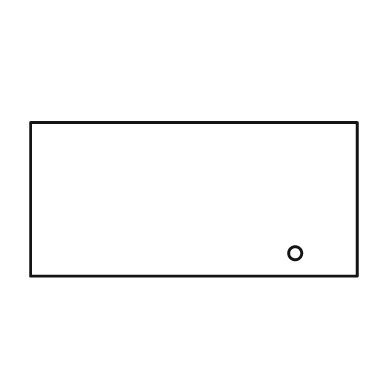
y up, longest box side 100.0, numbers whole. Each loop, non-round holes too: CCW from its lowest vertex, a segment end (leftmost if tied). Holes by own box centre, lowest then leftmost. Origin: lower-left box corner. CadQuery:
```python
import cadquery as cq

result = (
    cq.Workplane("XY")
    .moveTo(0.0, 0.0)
    .lineTo(100.0, 0.0)
    .lineTo(100.0, 47.0)
    .lineTo(0.0, 47.0)
    .close()
    .moveTo(81.0, 7.0)
    .circle(2.0)
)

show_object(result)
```